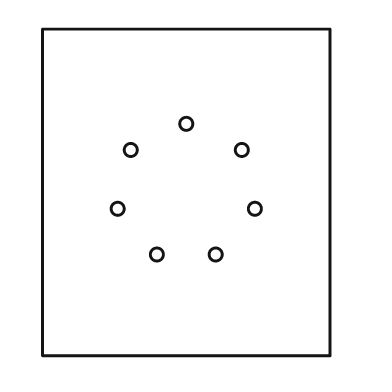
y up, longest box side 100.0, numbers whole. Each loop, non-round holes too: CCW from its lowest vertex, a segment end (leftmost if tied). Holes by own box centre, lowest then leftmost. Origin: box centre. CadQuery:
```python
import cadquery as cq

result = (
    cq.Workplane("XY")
    .moveTo(-44.0, -50.0)
    .lineTo(44.0, -50.0)
    .lineTo(44.0, 50.0)
    .lineTo(-44.0, 50.0)
    .close()
    .moveTo(-9.0, -19.0)
    .circle(2.0)
    .moveTo(9.0, -19.0)
    .circle(2.0)
    .moveTo(-21.0, -5.0)
    .circle(2.0)
    .moveTo(21.0, -5.0)
    .circle(2.0)
    .moveTo(-17.0, 13.0)
    .circle(2.0)
    .moveTo(17.0, 13.0)
    .circle(2.0)
    .moveTo(0.0, 21.0)
    .circle(2.0)
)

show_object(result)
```